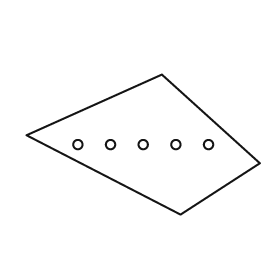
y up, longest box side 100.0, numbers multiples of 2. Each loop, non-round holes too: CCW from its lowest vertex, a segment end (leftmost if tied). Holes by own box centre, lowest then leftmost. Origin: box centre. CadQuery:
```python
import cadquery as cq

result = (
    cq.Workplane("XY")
    .moveTo(16.0, -30.0)
    .lineTo(50.0, -8.0)
    .lineTo(8.0, 30.0)
    .lineTo(-50.0, 4.0)
    .close()
    .moveTo(-28.0, 0.0)
    .circle(2.0)
    .moveTo(-14.0, 0.0)
    .circle(2.0)
    .moveTo(0.0, 0.0)
    .circle(2.0)
    .moveTo(14.0, 0.0)
    .circle(2.0)
    .moveTo(28.0, 0.0)
    .circle(2.0)
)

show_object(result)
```